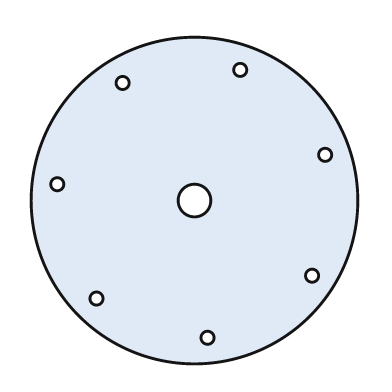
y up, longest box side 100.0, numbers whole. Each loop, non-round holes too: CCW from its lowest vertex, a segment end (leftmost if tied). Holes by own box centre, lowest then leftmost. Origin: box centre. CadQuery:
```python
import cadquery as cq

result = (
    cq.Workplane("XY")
    .moveTo(0.0, 0.0)
    .circle(50.0)
    .moveTo(4.0, -42.0)
    .circle(2.0)
    .moveTo(-30.0, -30.0)
    .circle(2.0)
    .moveTo(36.0, -23.0)
    .circle(2.0)
    .moveTo(0.0, 0.0)
    .circle(5.0)
    .moveTo(-42.0, 5.0)
    .circle(2.0)
    .moveTo(40.0, 14.0)
    .circle(2.0)
    .moveTo(-22.0, 36.0)
    .circle(2.0)
    .moveTo(14.0, 40.0)
    .circle(2.0)
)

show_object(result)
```